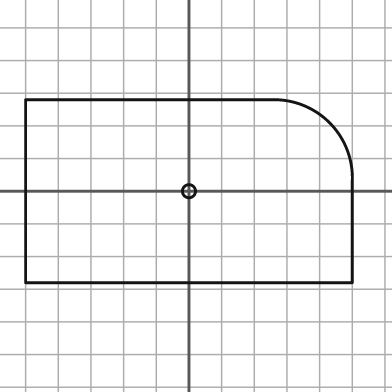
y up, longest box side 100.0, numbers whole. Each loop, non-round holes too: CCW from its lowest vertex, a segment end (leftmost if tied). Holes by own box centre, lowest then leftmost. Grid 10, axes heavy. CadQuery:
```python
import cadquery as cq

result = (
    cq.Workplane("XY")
    .moveTo(-50.0, -28.0)
    .lineTo(50.0, -28.0)
    .lineTo(50.0, 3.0)
    .threePointArc((43.0, 21.0), (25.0, 28.0))
    .lineTo(-50.0, 28.0)
    .close()
    .moveTo(0.0, 0.0)
    .circle(2.0)
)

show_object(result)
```